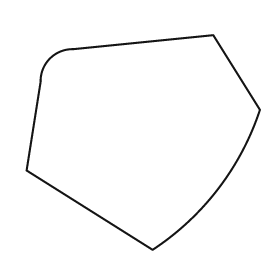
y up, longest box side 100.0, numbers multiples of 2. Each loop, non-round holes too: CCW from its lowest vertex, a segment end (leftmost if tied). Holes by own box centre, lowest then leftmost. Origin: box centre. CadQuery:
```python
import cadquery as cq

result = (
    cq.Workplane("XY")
    .moveTo(4.0, -46.0)
    .threePointArc((32.0, -20.0), (50.0, 14.0))
    .lineTo(30.0, 46.0)
    .lineTo(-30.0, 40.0)
    .threePointArc((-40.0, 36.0), (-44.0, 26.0))
    .lineTo(-50.0, -12.0)
    .close()
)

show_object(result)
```